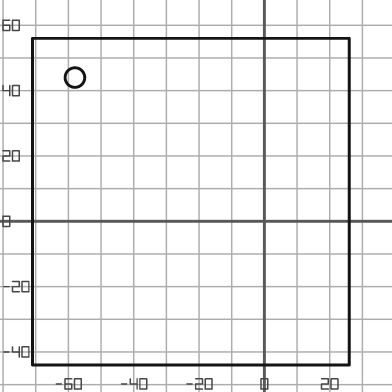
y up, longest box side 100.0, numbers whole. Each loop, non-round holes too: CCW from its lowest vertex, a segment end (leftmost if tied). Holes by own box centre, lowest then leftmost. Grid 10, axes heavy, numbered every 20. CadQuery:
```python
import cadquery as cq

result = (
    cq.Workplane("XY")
    .moveTo(-71.0, -44.0)
    .lineTo(26.0, -44.0)
    .lineTo(26.0, 56.0)
    .lineTo(-71.0, 56.0)
    .close()
    .moveTo(-58.0, 44.0)
    .circle(3.0)
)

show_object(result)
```